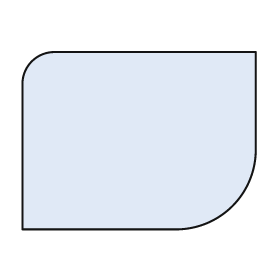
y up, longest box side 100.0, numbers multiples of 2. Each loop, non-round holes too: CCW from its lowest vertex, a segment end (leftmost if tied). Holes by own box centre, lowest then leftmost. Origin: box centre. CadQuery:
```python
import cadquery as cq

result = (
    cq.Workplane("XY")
    .moveTo(-50.0, -38.0)
    .lineTo(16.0, -38.0)
    .threePointArc((40.0, -28.0), (50.0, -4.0))
    .lineTo(50.0, 38.0)
    .lineTo(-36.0, 38.0)
    .threePointArc((-46.0, 34.0), (-50.0, 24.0))
    .close()
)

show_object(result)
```